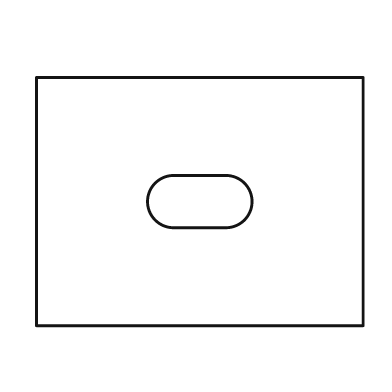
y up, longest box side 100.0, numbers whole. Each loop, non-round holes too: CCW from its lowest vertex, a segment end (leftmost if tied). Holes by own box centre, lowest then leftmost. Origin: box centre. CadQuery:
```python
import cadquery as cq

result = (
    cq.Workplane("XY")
    .moveTo(-50.0, -38.0)
    .lineTo(50.0, -38.0)
    .lineTo(50.0, 38.0)
    .lineTo(-50.0, 38.0)
    .close()
    .moveTo(-8.0, -8.0)
    .lineTo(8.0, -8.0)
    .threePointArc((16.0, 0.0), (8.0, 8.0))
    .lineTo(-8.0, 8.0)
    .threePointArc((-16.0, 0.0), (-8.0, -8.0))
    .close()
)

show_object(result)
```